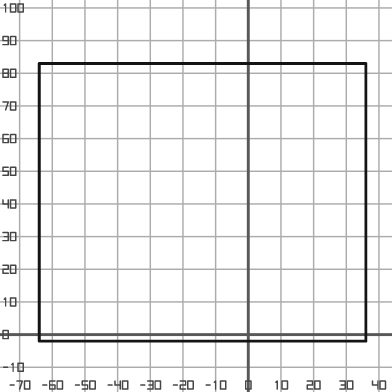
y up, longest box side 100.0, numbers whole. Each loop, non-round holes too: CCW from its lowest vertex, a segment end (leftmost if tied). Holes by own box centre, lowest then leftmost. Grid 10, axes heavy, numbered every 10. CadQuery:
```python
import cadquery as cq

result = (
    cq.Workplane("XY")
    .moveTo(-64.0, -2.0)
    .lineTo(36.0, -2.0)
    .lineTo(36.0, 83.0)
    .lineTo(-64.0, 83.0)
    .close()
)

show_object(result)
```